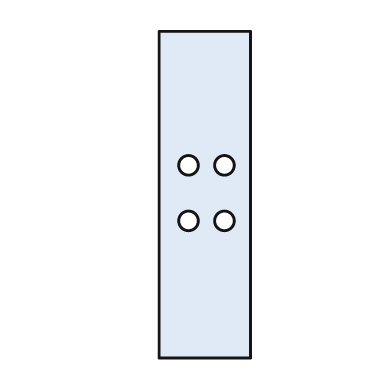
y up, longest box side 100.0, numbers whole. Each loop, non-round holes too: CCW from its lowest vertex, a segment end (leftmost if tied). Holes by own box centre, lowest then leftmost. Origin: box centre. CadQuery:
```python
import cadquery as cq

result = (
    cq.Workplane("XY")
    .moveTo(-14.0, -50.0)
    .lineTo(14.0, -50.0)
    .lineTo(14.0, 50.0)
    .lineTo(-14.0, 50.0)
    .close()
    .moveTo(-5.0, -8.0)
    .circle(3.0)
    .moveTo(6.0, -8.0)
    .circle(3.0)
    .moveTo(-5.0, 9.0)
    .circle(3.0)
    .moveTo(6.0, 9.0)
    .circle(3.0)
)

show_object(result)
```